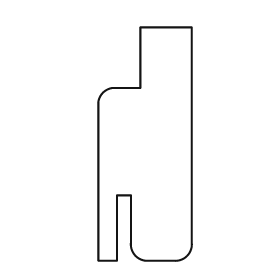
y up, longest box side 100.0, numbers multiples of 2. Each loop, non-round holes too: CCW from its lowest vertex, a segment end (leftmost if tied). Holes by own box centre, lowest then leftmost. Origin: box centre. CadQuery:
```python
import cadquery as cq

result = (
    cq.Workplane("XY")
    .moveTo(-20.0, -50.0)
    .lineTo(-12.0, -50.0)
    .lineTo(-12.0, -22.0)
    .lineTo(-6.0, -22.0)
    .lineTo(-6.0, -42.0)
    .threePointArc((-4.0, -48.0), (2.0, -50.0))
    .lineTo(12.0, -50.0)
    .threePointArc((18.0, -48.0), (20.0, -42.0))
    .lineTo(20.0, 50.0)
    .lineTo(-2.0, 50.0)
    .lineTo(-2.0, 24.0)
    .lineTo(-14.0, 24.0)
    .threePointArc((-18.0, 22.0), (-20.0, 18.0))
    .close()
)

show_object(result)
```